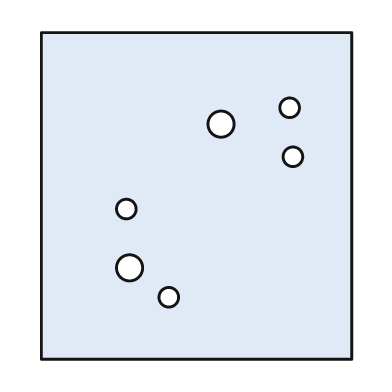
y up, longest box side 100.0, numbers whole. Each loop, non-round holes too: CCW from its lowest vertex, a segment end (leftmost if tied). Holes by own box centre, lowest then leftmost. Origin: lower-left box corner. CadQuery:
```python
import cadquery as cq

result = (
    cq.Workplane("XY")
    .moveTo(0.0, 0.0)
    .lineTo(95.0, 0.0)
    .lineTo(95.0, 100.0)
    .lineTo(0.0, 100.0)
    .close()
    .moveTo(39.0, 19.0)
    .circle(3.0)
    .moveTo(27.0, 28.0)
    .circle(4.0)
    .moveTo(26.0, 46.0)
    .circle(3.0)
    .moveTo(77.0, 62.0)
    .circle(3.0)
    .moveTo(55.0, 72.0)
    .circle(4.0)
    .moveTo(76.0, 77.0)
    .circle(3.0)
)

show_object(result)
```